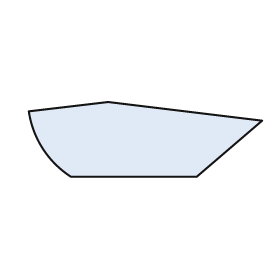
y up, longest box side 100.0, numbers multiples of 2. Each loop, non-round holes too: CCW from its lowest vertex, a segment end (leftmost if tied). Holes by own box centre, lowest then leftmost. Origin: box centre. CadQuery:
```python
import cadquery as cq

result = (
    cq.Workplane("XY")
    .moveTo(-32.0, -16.0)
    .lineTo(22.0, -16.0)
    .lineTo(50.0, 8.0)
    .lineTo(-16.0, 16.0)
    .lineTo(-50.0, 12.0)
    .threePointArc((-44.0, -4.0), (-32.0, -16.0))
    .close()
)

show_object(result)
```